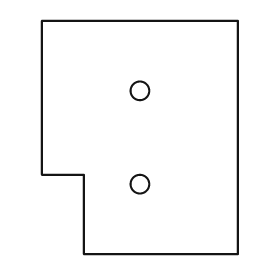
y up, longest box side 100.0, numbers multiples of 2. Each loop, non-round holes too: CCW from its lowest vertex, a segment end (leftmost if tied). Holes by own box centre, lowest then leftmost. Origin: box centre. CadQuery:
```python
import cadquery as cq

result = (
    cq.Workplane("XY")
    .moveTo(-24.0, -50.0)
    .lineTo(42.0, -50.0)
    .lineTo(42.0, 50.0)
    .lineTo(-42.0, 50.0)
    .lineTo(-42.0, -16.0)
    .lineTo(-24.0, -16.0)
    .close()
    .moveTo(0.0, -20.0)
    .circle(4.0)
    .moveTo(0.0, 20.0)
    .circle(4.0)
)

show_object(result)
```